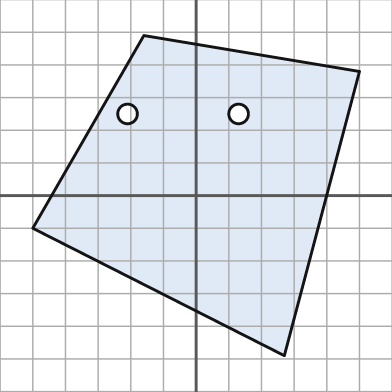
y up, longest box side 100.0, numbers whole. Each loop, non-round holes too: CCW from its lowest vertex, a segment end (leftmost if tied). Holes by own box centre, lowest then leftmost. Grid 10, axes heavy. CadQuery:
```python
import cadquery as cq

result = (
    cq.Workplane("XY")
    .moveTo(27.0, -49.0)
    .lineTo(50.0, 38.0)
    .lineTo(-16.0, 49.0)
    .lineTo(-50.0, -10.0)
    .close()
    .moveTo(-21.0, 25.0)
    .circle(3.0)
    .moveTo(13.0, 25.0)
    .circle(3.0)
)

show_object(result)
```